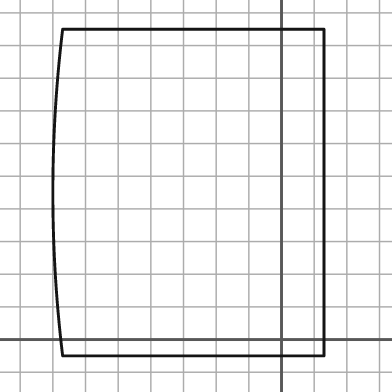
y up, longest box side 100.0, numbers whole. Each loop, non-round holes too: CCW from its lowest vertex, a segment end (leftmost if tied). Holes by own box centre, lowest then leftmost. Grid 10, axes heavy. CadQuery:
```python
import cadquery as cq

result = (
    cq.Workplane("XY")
    .moveTo(-67.0, -5.0)
    .lineTo(13.0, -5.0)
    .lineTo(13.0, 95.0)
    .lineTo(-67.0, 95.0)
    .threePointArc((-70.0, 45.0), (-67.0, -5.0))
    .close()
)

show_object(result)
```